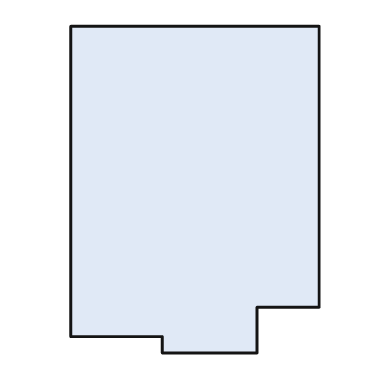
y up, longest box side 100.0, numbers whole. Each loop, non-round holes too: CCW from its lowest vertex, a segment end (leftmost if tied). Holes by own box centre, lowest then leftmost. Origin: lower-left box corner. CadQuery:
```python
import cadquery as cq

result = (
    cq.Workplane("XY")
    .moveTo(28.0, 0.0)
    .lineTo(57.0, 0.0)
    .lineTo(57.0, 14.0)
    .lineTo(76.0, 14.0)
    .lineTo(76.0, 100.0)
    .lineTo(0.0, 100.0)
    .lineTo(0.0, 5.0)
    .lineTo(28.0, 5.0)
    .close()
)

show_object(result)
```